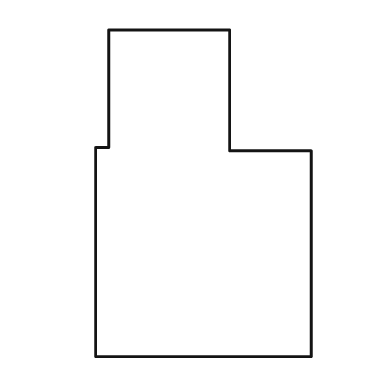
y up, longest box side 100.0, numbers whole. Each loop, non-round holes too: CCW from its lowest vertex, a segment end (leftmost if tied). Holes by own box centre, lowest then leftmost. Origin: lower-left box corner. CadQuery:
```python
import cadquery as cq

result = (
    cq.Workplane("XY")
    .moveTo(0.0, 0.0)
    .lineTo(66.0, 0.0)
    .lineTo(66.0, 63.0)
    .lineTo(41.0, 63.0)
    .lineTo(41.0, 100.0)
    .lineTo(4.0, 100.0)
    .lineTo(4.0, 64.0)
    .lineTo(0.0, 64.0)
    .close()
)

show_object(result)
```